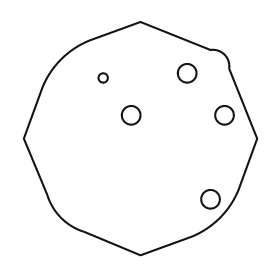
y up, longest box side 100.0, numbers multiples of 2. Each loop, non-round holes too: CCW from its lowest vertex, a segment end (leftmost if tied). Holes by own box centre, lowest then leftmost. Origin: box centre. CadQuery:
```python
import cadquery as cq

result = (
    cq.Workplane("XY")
    .moveTo(0.0, -50.0)
    .lineTo(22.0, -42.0)
    .threePointArc((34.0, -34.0), (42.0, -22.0))
    .lineTo(50.0, 0.0)
    .lineTo(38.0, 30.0)
    .threePointArc((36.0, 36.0), (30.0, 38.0))
    .lineTo(0.0, 50.0)
    .lineTo(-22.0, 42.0)
    .threePointArc((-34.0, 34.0), (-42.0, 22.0))
    .lineTo(-50.0, 0.0)
    .lineTo(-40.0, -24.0)
    .threePointArc((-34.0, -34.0), (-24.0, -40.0))
    .close()
    .moveTo(30.0, -26.0)
    .circle(4.0)
    .moveTo(-4.0, 10.0)
    .circle(4.0)
    .moveTo(36.0, 10.0)
    .circle(4.0)
    .moveTo(-16.0, 26.0)
    .circle(2.0)
    .moveTo(20.0, 28.0)
    .circle(4.0)
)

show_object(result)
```